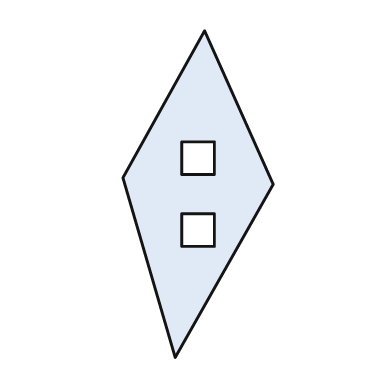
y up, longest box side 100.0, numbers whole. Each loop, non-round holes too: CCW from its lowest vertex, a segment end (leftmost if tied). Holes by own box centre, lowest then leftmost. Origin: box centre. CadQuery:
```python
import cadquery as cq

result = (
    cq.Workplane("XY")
    .moveTo(-7.0, -50.0)
    .lineTo(23.0, 3.0)
    .lineTo(2.0, 50.0)
    .lineTo(-23.0, 5.0)
    .close()
    .moveTo(-5.0, -16.0)
    .lineTo(5.0, -16.0)
    .lineTo(5.0, -6.0)
    .lineTo(-5.0, -6.0)
    .close()
    .moveTo(-5.0, 6.0)
    .lineTo(5.0, 6.0)
    .lineTo(5.0, 16.0)
    .lineTo(-5.0, 16.0)
    .close()
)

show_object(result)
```